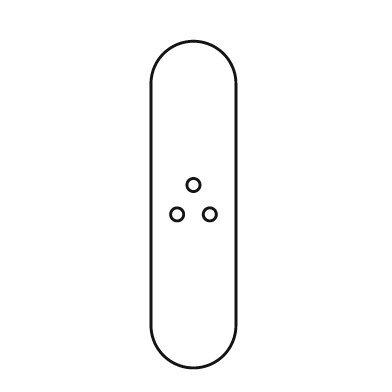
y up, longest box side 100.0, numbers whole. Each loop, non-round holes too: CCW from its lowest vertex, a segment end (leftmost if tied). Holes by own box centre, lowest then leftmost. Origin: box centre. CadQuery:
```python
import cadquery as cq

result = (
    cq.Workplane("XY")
    .moveTo(-13.0, -37.0)
    .threePointArc((0.0, -50.0), (13.0, -37.0))
    .lineTo(13.0, 37.0)
    .threePointArc((0.0, 50.0), (-13.0, 37.0))
    .close()
    .moveTo(-5.0, -3.0)
    .circle(2.0)
    .moveTo(5.0, -3.0)
    .circle(2.0)
    .moveTo(0.0, 6.0)
    .circle(2.0)
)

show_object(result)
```